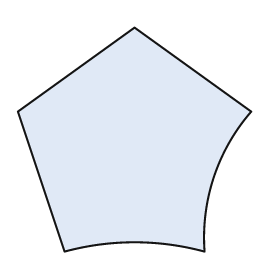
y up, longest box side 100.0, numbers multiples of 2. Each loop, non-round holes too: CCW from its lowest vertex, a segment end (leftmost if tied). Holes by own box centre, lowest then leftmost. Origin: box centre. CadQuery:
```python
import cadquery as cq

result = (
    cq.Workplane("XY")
    .moveTo(-30.0, -48.0)
    .threePointArc((0.0, -44.0), (30.0, -48.0))
    .threePointArc((34.0, -16.0), (50.0, 12.0))
    .lineTo(0.0, 48.0)
    .lineTo(-50.0, 12.0)
    .close()
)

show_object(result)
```